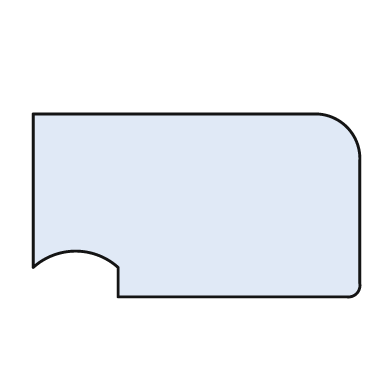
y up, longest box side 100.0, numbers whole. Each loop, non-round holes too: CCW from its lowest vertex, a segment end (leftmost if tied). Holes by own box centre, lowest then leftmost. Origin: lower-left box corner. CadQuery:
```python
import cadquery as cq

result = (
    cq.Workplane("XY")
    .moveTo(26.0, 0.0)
    .lineTo(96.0, 0.0)
    .threePointArc((99.0, 1.0), (100.0, 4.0))
    .lineTo(100.0, 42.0)
    .threePointArc((96.0, 52.0), (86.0, 56.0))
    .lineTo(0.0, 56.0)
    .lineTo(0.0, 9.0)
    .threePointArc((13.0, 14.0), (26.0, 9.0))
    .close()
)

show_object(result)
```